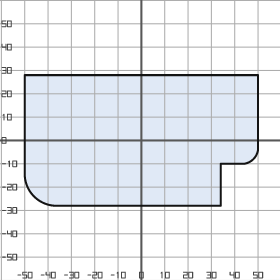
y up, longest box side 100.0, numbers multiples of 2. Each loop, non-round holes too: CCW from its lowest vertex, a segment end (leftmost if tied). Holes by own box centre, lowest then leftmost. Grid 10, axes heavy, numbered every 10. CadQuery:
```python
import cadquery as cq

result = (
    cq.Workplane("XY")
    .moveTo(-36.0, -28.0)
    .lineTo(34.0, -28.0)
    .lineTo(34.0, -10.0)
    .lineTo(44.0, -10.0)
    .threePointArc((48.0, -8.0), (50.0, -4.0))
    .lineTo(50.0, 28.0)
    .lineTo(-50.0, 28.0)
    .lineTo(-50.0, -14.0)
    .threePointArc((-46.0, -24.0), (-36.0, -28.0))
    .close()
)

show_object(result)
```